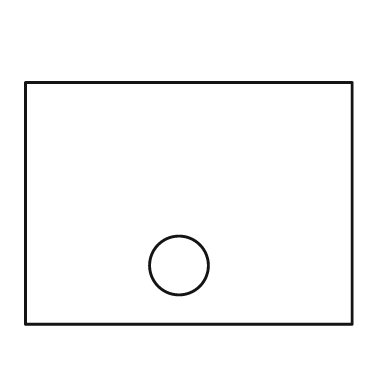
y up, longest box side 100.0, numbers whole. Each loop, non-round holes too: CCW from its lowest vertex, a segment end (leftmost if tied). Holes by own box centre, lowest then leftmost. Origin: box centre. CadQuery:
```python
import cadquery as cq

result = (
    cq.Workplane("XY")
    .moveTo(-50.0, -37.0)
    .lineTo(50.0, -37.0)
    .lineTo(50.0, 37.0)
    .lineTo(-50.0, 37.0)
    .close()
    .moveTo(-3.0, -19.0)
    .circle(9.0)
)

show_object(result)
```